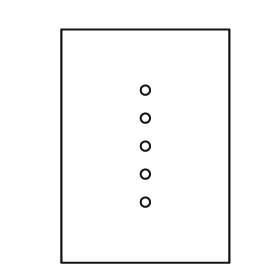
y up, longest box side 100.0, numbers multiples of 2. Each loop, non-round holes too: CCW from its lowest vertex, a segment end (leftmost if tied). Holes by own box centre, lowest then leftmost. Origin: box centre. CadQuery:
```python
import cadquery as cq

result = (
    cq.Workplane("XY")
    .moveTo(-36.0, -50.0)
    .lineTo(36.0, -50.0)
    .lineTo(36.0, 50.0)
    .lineTo(-36.0, 50.0)
    .close()
    .moveTo(0.0, -24.0)
    .circle(2.0)
    .moveTo(0.0, -12.0)
    .circle(2.0)
    .moveTo(0.0, 0.0)
    .circle(2.0)
    .moveTo(0.0, 12.0)
    .circle(2.0)
    .moveTo(0.0, 24.0)
    .circle(2.0)
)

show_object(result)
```